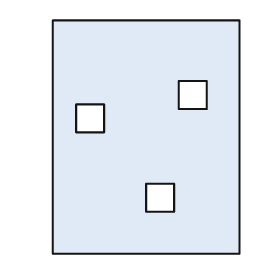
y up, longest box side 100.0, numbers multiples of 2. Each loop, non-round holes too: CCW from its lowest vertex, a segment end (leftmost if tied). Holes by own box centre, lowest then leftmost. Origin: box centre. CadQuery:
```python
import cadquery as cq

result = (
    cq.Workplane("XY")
    .moveTo(-40.0, -50.0)
    .lineTo(40.0, -50.0)
    .lineTo(40.0, 50.0)
    .lineTo(-40.0, 50.0)
    .close()
    .moveTo(0.0, -32.0)
    .lineTo(12.0, -32.0)
    .lineTo(12.0, -20.0)
    .lineTo(0.0, -20.0)
    .close()
    .moveTo(-30.0, 2.0)
    .lineTo(-18.0, 2.0)
    .lineTo(-18.0, 14.0)
    .lineTo(-30.0, 14.0)
    .close()
    .moveTo(14.0, 12.0)
    .lineTo(26.0, 12.0)
    .lineTo(26.0, 24.0)
    .lineTo(14.0, 24.0)
    .close()
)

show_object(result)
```